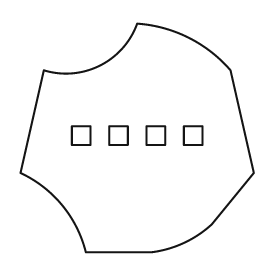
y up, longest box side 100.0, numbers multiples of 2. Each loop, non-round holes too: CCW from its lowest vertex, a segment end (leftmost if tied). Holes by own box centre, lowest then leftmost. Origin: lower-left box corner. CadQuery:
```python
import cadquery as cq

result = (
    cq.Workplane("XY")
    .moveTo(28.0, 0.0)
    .lineTo(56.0, 0.0)
    .threePointArc((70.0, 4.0), (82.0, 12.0))
    .lineTo(100.0, 34.0)
    .lineTo(90.0, 78.0)
    .threePointArc((72.0, 92.0), (50.0, 98.0))
    .threePointArc((34.0, 80.0), (10.0, 78.0))
    .lineTo(0.0, 34.0)
    .threePointArc((18.0, 20.0), (28.0, 0.0))
    .close()
    .moveTo(22.0, 46.0)
    .lineTo(30.0, 46.0)
    .lineTo(30.0, 54.0)
    .lineTo(22.0, 54.0)
    .close()
    .moveTo(38.0, 46.0)
    .lineTo(46.0, 46.0)
    .lineTo(46.0, 54.0)
    .lineTo(38.0, 54.0)
    .close()
    .moveTo(54.0, 46.0)
    .lineTo(62.0, 46.0)
    .lineTo(62.0, 54.0)
    .lineTo(54.0, 54.0)
    .close()
    .moveTo(70.0, 46.0)
    .lineTo(78.0, 46.0)
    .lineTo(78.0, 54.0)
    .lineTo(70.0, 54.0)
    .close()
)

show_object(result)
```